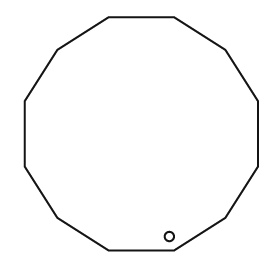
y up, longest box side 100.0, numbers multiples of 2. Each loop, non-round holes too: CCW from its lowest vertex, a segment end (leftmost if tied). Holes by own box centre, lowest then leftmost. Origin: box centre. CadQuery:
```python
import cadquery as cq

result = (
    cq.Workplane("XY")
    .moveTo(-14.0, -50.0)
    .lineTo(14.0, -50.0)
    .lineTo(36.0, -36.0)
    .lineTo(50.0, -14.0)
    .lineTo(50.0, 14.0)
    .lineTo(36.0, 36.0)
    .lineTo(14.0, 50.0)
    .lineTo(-14.0, 50.0)
    .lineTo(-36.0, 36.0)
    .lineTo(-50.0, 14.0)
    .lineTo(-50.0, -14.0)
    .lineTo(-36.0, -36.0)
    .close()
    .moveTo(12.0, -44.0)
    .circle(2.0)
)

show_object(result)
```